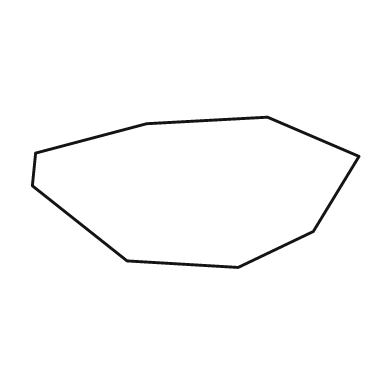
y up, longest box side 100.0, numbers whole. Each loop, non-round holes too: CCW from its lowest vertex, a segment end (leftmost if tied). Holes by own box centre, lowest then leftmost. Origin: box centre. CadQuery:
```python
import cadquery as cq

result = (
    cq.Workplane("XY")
    .moveTo(13.0, -23.0)
    .lineTo(36.0, -12.0)
    .lineTo(50.0, 11.0)
    .lineTo(22.0, 23.0)
    .lineTo(-15.0, 21.0)
    .lineTo(-49.0, 12.0)
    .lineTo(-50.0, 2.0)
    .lineTo(-21.0, -21.0)
    .close()
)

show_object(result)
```